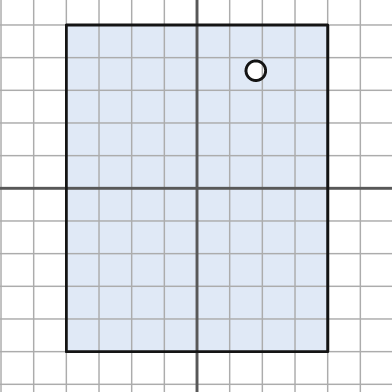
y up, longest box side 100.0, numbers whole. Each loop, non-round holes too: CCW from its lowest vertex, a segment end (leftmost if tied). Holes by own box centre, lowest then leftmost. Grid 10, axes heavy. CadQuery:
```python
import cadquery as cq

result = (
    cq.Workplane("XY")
    .moveTo(-40.0, -50.0)
    .lineTo(40.0, -50.0)
    .lineTo(40.0, 50.0)
    .lineTo(-40.0, 50.0)
    .close()
    .moveTo(18.0, 36.0)
    .circle(3.0)
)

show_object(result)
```